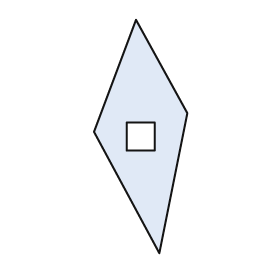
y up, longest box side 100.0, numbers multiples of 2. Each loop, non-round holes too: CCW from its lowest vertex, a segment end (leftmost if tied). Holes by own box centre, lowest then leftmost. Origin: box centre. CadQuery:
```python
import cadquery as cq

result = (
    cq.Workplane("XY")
    .moveTo(8.0, -50.0)
    .lineTo(20.0, 10.0)
    .lineTo(-2.0, 50.0)
    .lineTo(-20.0, 2.0)
    .close()
    .moveTo(-6.0, -6.0)
    .lineTo(6.0, -6.0)
    .lineTo(6.0, 6.0)
    .lineTo(-6.0, 6.0)
    .close()
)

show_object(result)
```